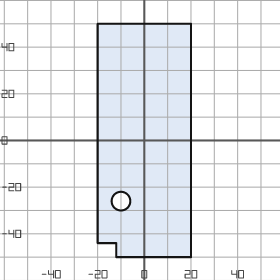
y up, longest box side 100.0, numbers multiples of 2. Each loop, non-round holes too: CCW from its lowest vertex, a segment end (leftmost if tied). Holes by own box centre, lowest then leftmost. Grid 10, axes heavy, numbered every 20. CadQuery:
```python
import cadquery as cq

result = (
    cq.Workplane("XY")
    .moveTo(-12.0, -50.0)
    .lineTo(20.0, -50.0)
    .lineTo(20.0, 50.0)
    .lineTo(-20.0, 50.0)
    .lineTo(-20.0, -44.0)
    .lineTo(-12.0, -44.0)
    .close()
    .moveTo(-10.0, -26.0)
    .circle(4.0)
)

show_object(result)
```